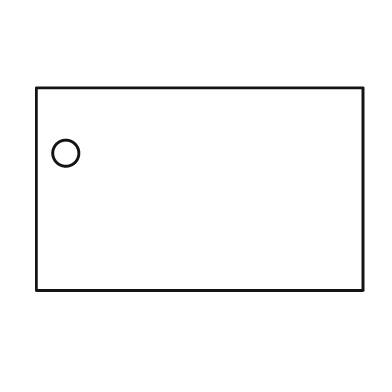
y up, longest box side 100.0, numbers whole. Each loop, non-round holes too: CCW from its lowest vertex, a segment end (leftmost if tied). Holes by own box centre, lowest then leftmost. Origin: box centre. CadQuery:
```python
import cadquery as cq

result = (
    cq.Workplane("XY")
    .moveTo(-50.0, -31.0)
    .lineTo(50.0, -31.0)
    .lineTo(50.0, 31.0)
    .lineTo(-50.0, 31.0)
    .close()
    .moveTo(-41.0, 11.0)
    .circle(4.0)
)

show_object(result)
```